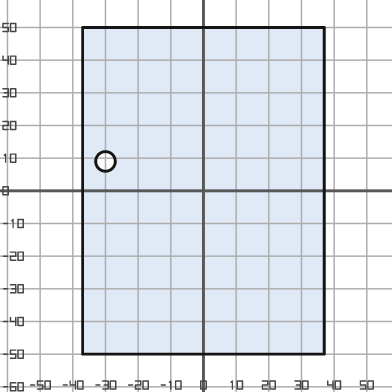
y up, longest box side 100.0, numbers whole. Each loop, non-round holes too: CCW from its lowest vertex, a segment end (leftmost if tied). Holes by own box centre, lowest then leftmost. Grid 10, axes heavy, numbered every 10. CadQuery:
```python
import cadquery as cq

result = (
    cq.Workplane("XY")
    .moveTo(-37.0, -50.0)
    .lineTo(37.0, -50.0)
    .lineTo(37.0, 50.0)
    .lineTo(-37.0, 50.0)
    .close()
    .moveTo(-30.0, 9.0)
    .circle(3.0)
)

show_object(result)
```